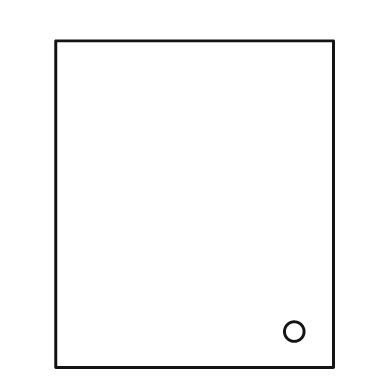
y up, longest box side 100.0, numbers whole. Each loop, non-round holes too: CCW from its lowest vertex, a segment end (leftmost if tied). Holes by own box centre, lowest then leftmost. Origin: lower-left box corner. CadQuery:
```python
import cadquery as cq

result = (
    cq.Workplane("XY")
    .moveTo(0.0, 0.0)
    .lineTo(85.0, 0.0)
    .lineTo(85.0, 100.0)
    .lineTo(0.0, 100.0)
    .close()
    .moveTo(73.0, 11.0)
    .circle(3.0)
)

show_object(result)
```